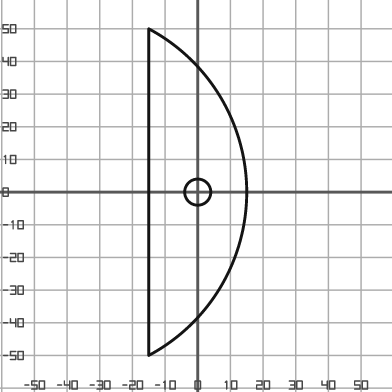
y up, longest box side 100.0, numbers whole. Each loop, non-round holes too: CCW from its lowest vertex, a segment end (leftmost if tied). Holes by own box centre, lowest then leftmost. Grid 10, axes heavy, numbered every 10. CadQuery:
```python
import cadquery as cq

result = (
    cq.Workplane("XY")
    .moveTo(-15.0, -50.0)
    .threePointArc((15.0, 0.0), (-15.0, 50.0))
    .close()
    .moveTo(0.0, 0.0)
    .circle(4.0)
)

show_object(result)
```